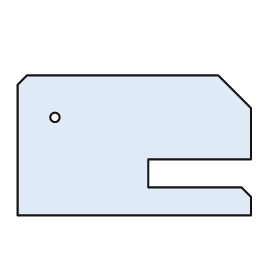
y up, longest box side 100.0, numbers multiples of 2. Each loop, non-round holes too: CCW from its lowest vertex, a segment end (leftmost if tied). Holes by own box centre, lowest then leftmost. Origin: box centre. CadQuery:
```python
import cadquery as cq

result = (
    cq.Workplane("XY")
    .moveTo(-50.0, -30.0)
    .lineTo(50.0, -30.0)
    .lineTo(50.0, -22.0)
    .lineTo(46.0, -18.0)
    .lineTo(6.0, -18.0)
    .lineTo(6.0, -6.0)
    .lineTo(50.0, -6.0)
    .lineTo(50.0, 16.0)
    .lineTo(36.0, 30.0)
    .lineTo(-46.0, 30.0)
    .lineTo(-50.0, 26.0)
    .close()
    .moveTo(-34.0, 12.0)
    .circle(2.0)
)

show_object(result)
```